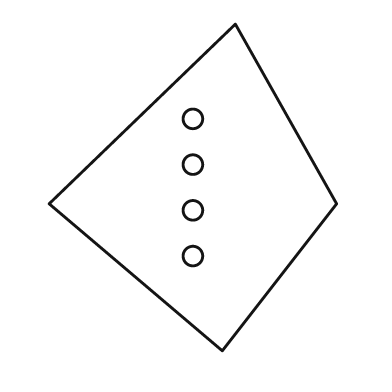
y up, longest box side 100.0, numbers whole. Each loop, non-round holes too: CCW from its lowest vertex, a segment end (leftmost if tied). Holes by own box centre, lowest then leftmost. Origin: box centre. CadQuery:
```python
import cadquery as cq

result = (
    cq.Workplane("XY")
    .moveTo(9.0, -50.0)
    .lineTo(44.0, -5.0)
    .lineTo(13.0, 50.0)
    .lineTo(-44.0, -5.0)
    .close()
    .moveTo(0.0, -21.0)
    .circle(3.0)
    .moveTo(0.0, -7.0)
    .circle(3.0)
    .moveTo(0.0, 7.0)
    .circle(3.0)
    .moveTo(0.0, 21.0)
    .circle(3.0)
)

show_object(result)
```